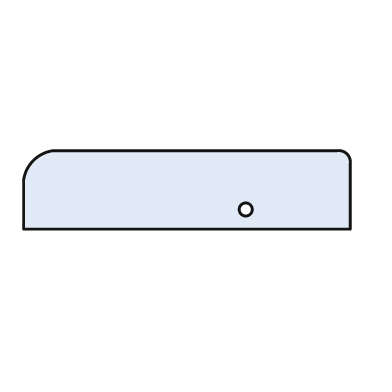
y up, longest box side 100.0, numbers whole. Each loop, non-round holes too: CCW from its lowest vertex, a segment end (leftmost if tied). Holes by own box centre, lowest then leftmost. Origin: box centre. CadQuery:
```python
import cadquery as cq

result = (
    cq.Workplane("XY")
    .moveTo(-50.0, -12.0)
    .lineTo(50.0, -12.0)
    .lineTo(50.0, 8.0)
    .threePointArc((49.0, 11.0), (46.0, 12.0))
    .lineTo(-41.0, 12.0)
    .threePointArc((-47.0, 9.0), (-50.0, 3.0))
    .close()
    .moveTo(18.0, -6.0)
    .circle(2.0)
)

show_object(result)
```